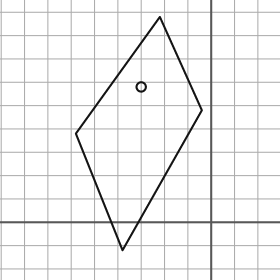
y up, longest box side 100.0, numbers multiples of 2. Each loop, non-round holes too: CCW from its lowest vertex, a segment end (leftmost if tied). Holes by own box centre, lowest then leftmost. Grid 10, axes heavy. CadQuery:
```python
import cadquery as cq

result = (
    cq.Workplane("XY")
    .moveTo(-38.0, -12.0)
    .lineTo(-4.0, 48.0)
    .lineTo(-22.0, 88.0)
    .lineTo(-58.0, 38.0)
    .close()
    .moveTo(-30.0, 58.0)
    .circle(2.0)
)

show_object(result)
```